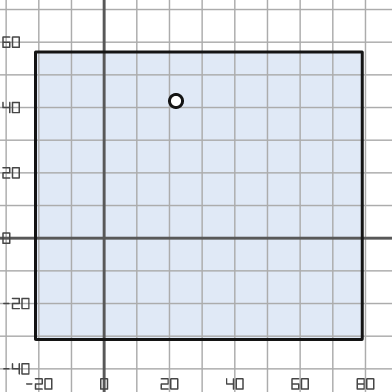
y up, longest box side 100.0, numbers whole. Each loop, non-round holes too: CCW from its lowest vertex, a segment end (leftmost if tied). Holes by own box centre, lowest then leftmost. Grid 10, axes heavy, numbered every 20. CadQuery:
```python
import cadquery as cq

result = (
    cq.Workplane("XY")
    .moveTo(-21.0, -31.0)
    .lineTo(79.0, -31.0)
    .lineTo(79.0, 57.0)
    .lineTo(-21.0, 57.0)
    .close()
    .moveTo(22.0, 42.0)
    .circle(2.0)
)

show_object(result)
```